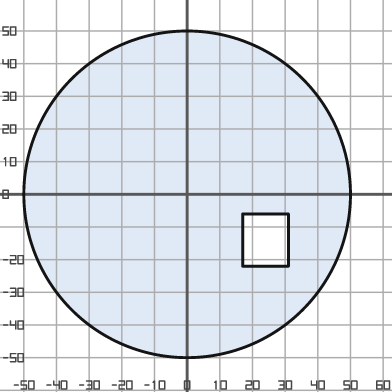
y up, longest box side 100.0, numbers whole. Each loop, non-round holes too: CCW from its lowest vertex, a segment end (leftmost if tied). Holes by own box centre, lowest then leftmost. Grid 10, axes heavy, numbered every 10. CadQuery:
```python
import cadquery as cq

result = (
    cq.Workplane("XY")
    .moveTo(0.0, 0.0)
    .circle(50.0)
    .moveTo(17.0, -22.0)
    .lineTo(31.0, -22.0)
    .lineTo(31.0, -6.0)
    .lineTo(17.0, -6.0)
    .close()
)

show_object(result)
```